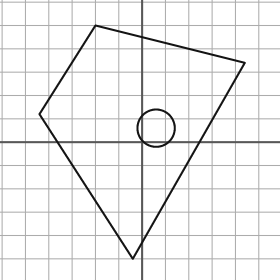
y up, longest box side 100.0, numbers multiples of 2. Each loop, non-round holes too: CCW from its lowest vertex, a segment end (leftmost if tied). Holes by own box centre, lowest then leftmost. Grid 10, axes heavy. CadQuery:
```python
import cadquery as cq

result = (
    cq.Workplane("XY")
    .moveTo(-4.0, -50.0)
    .lineTo(44.0, 34.0)
    .lineTo(-20.0, 50.0)
    .lineTo(-44.0, 12.0)
    .close()
    .moveTo(6.0, 6.0)
    .circle(8.0)
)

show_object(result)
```